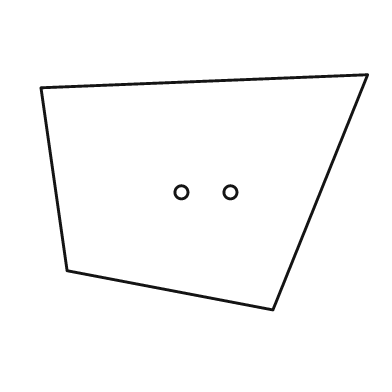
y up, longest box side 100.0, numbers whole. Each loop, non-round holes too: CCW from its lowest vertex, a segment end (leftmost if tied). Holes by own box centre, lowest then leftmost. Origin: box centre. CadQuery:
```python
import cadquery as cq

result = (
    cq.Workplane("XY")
    .moveTo(21.0, -36.0)
    .lineTo(50.0, 36.0)
    .lineTo(-50.0, 32.0)
    .lineTo(-42.0, -24.0)
    .close()
    .moveTo(-7.0, 0.0)
    .circle(2.0)
    .moveTo(8.0, 0.0)
    .circle(2.0)
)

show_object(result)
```